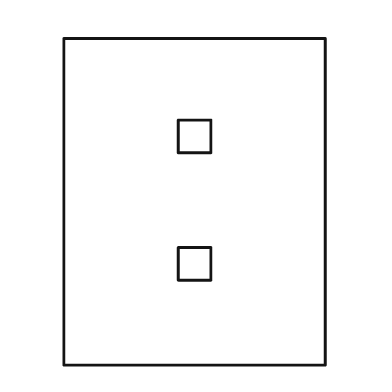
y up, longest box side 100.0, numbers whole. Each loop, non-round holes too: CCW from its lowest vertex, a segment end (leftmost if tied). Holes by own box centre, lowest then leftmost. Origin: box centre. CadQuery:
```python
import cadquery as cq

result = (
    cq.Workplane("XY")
    .moveTo(-40.0, -50.0)
    .lineTo(40.0, -50.0)
    .lineTo(40.0, 50.0)
    .lineTo(-40.0, 50.0)
    .close()
    .moveTo(-5.0, -24.0)
    .lineTo(5.0, -24.0)
    .lineTo(5.0, -14.0)
    .lineTo(-5.0, -14.0)
    .close()
    .moveTo(-5.0, 15.0)
    .lineTo(5.0, 15.0)
    .lineTo(5.0, 25.0)
    .lineTo(-5.0, 25.0)
    .close()
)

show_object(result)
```